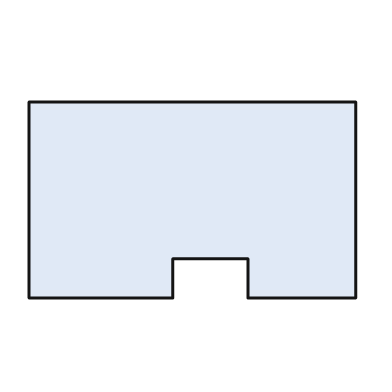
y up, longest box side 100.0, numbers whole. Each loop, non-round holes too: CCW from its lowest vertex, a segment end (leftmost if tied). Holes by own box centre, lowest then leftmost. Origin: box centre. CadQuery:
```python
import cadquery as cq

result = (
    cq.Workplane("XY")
    .moveTo(-50.0, -30.0)
    .lineTo(-6.0, -30.0)
    .lineTo(-6.0, -18.0)
    .lineTo(17.0, -18.0)
    .lineTo(17.0, -30.0)
    .lineTo(50.0, -30.0)
    .lineTo(50.0, 30.0)
    .lineTo(-50.0, 30.0)
    .close()
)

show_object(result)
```